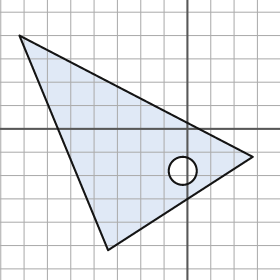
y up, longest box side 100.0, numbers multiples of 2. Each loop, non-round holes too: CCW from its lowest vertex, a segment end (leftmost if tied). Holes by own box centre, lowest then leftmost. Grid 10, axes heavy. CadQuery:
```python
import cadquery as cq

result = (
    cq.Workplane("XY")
    .moveTo(-34.0, -52.0)
    .lineTo(28.0, -12.0)
    .lineTo(-72.0, 40.0)
    .close()
    .moveTo(-2.0, -18.0)
    .circle(6.0)
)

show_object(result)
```